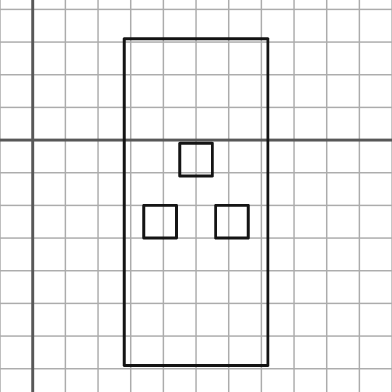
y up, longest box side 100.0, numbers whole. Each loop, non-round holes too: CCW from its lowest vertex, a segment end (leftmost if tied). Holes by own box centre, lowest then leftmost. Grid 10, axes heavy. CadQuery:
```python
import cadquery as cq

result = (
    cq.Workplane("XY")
    .moveTo(28.0, -69.0)
    .lineTo(72.0, -69.0)
    .lineTo(72.0, 31.0)
    .lineTo(28.0, 31.0)
    .close()
    .moveTo(34.0, -30.0)
    .lineTo(44.0, -30.0)
    .lineTo(44.0, -20.0)
    .lineTo(34.0, -20.0)
    .close()
    .moveTo(56.0, -30.0)
    .lineTo(66.0, -30.0)
    .lineTo(66.0, -20.0)
    .lineTo(56.0, -20.0)
    .close()
    .moveTo(45.0, -11.0)
    .lineTo(55.0, -11.0)
    .lineTo(55.0, -1.0)
    .lineTo(45.0, -1.0)
    .close()
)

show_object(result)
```